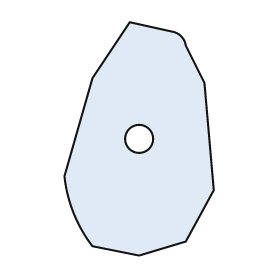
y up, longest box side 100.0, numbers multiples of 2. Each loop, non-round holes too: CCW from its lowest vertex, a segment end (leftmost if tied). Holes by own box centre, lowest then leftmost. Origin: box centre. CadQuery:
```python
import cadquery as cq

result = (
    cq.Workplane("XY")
    .moveTo(0.0, -50.0)
    .lineTo(20.0, -44.0)
    .lineTo(32.0, -22.0)
    .lineTo(28.0, 24.0)
    .lineTo(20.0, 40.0)
    .threePointArc((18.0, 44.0), (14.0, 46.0))
    .lineTo(-4.0, 50.0)
    .lineTo(-20.0, 26.0)
    .lineTo(-32.0, -16.0)
    .threePointArc((-28.0, -32.0), (-20.0, -46.0))
    .close()
    .moveTo(0.0, 0.0)
    .circle(6.0)
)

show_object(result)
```